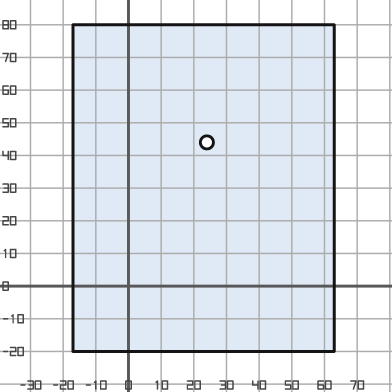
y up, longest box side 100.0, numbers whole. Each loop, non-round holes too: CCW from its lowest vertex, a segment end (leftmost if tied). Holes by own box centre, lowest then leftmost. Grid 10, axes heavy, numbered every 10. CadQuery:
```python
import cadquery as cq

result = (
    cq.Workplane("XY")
    .moveTo(-17.0, -20.0)
    .lineTo(63.0, -20.0)
    .lineTo(63.0, 80.0)
    .lineTo(-17.0, 80.0)
    .close()
    .moveTo(24.0, 44.0)
    .circle(2.0)
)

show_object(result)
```